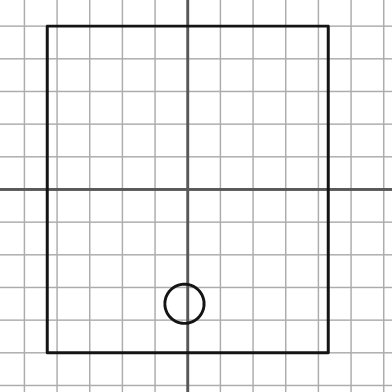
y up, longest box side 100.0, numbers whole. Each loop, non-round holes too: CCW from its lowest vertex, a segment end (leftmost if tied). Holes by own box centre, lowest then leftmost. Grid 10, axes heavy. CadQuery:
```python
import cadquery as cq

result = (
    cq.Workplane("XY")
    .moveTo(-43.0, -50.0)
    .lineTo(43.0, -50.0)
    .lineTo(43.0, 50.0)
    .lineTo(-43.0, 50.0)
    .close()
    .moveTo(-1.0, -35.0)
    .circle(6.0)
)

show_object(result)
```